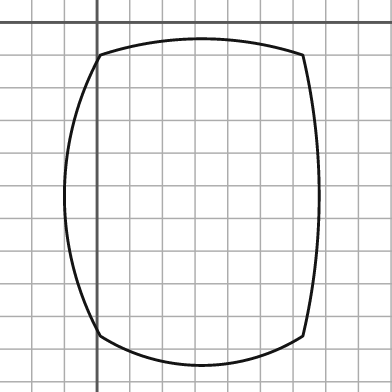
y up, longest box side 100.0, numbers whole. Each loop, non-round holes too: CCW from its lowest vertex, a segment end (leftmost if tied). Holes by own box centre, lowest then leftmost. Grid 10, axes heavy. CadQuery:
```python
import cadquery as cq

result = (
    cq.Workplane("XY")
    .moveTo(1.0, -96.0)
    .threePointArc((32.0, -105.0), (63.0, -96.0))
    .threePointArc((68.0, -53.0), (63.0, -10.0))
    .threePointArc((32.0, -5.0), (1.0, -10.0))
    .threePointArc((-10.0, -53.0), (1.0, -96.0))
    .close()
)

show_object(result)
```